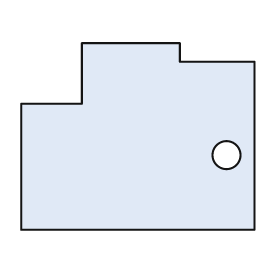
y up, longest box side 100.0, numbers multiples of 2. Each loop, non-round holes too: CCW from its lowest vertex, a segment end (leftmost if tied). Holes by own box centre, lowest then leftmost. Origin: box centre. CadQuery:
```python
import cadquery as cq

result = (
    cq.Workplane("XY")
    .moveTo(-50.0, -40.0)
    .lineTo(50.0, -40.0)
    .lineTo(50.0, 32.0)
    .lineTo(18.0, 32.0)
    .lineTo(18.0, 40.0)
    .lineTo(-24.0, 40.0)
    .lineTo(-24.0, 14.0)
    .lineTo(-50.0, 14.0)
    .close()
    .moveTo(38.0, -8.0)
    .circle(6.0)
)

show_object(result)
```